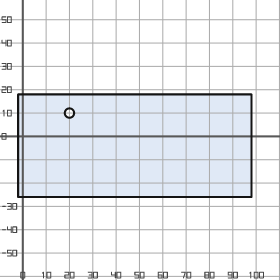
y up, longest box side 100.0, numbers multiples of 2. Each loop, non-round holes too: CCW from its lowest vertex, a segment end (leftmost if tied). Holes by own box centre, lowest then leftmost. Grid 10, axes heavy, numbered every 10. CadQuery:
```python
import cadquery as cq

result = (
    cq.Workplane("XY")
    .moveTo(-2.0, -26.0)
    .lineTo(98.0, -26.0)
    .lineTo(98.0, 18.0)
    .lineTo(-2.0, 18.0)
    .close()
    .moveTo(20.0, 10.0)
    .circle(2.0)
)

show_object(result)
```